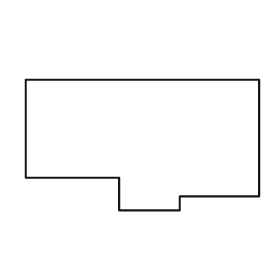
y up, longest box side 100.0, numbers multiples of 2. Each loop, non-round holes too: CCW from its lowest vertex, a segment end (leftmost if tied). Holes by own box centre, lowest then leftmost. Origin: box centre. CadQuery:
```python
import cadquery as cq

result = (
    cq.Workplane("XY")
    .moveTo(-10.0, -28.0)
    .lineTo(16.0, -28.0)
    .lineTo(16.0, -22.0)
    .lineTo(50.0, -22.0)
    .lineTo(50.0, 28.0)
    .lineTo(-50.0, 28.0)
    .lineTo(-50.0, -14.0)
    .lineTo(-10.0, -14.0)
    .close()
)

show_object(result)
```